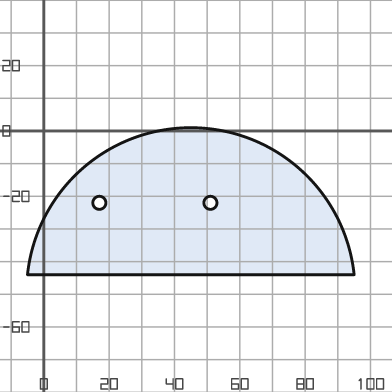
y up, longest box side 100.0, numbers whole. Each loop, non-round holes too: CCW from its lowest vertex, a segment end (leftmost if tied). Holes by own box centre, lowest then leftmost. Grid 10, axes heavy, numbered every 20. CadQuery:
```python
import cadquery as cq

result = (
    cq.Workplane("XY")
    .moveTo(-5.0, -44.0)
    .lineTo(95.0, -44.0)
    .threePointArc((45.0, 1.0), (-5.0, -44.0))
    .close()
    .moveTo(17.0, -22.0)
    .circle(2.0)
    .moveTo(51.0, -22.0)
    .circle(2.0)
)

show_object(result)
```